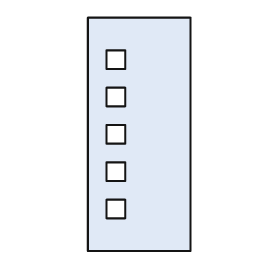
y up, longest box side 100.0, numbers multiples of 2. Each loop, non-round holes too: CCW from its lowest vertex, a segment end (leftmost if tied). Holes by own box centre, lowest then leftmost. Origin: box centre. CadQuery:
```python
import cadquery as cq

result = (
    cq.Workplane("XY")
    .moveTo(-22.0, -50.0)
    .lineTo(22.0, -50.0)
    .lineTo(22.0, 50.0)
    .lineTo(-22.0, 50.0)
    .close()
    .moveTo(-14.0, -36.0)
    .lineTo(-6.0, -36.0)
    .lineTo(-6.0, -28.0)
    .lineTo(-14.0, -28.0)
    .close()
    .moveTo(-14.0, -20.0)
    .lineTo(-6.0, -20.0)
    .lineTo(-6.0, -12.0)
    .lineTo(-14.0, -12.0)
    .close()
    .moveTo(-14.0, -4.0)
    .lineTo(-6.0, -4.0)
    .lineTo(-6.0, 4.0)
    .lineTo(-14.0, 4.0)
    .close()
    .moveTo(-14.0, 12.0)
    .lineTo(-6.0, 12.0)
    .lineTo(-6.0, 20.0)
    .lineTo(-14.0, 20.0)
    .close()
    .moveTo(-14.0, 28.0)
    .lineTo(-6.0, 28.0)
    .lineTo(-6.0, 36.0)
    .lineTo(-14.0, 36.0)
    .close()
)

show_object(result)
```